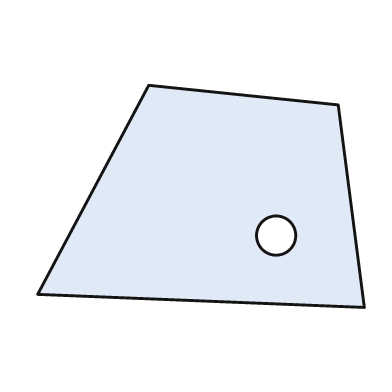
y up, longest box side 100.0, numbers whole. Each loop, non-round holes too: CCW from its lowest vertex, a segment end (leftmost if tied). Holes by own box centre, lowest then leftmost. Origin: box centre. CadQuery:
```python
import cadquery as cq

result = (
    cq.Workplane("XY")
    .moveTo(50.0, -34.0)
    .lineTo(42.0, 28.0)
    .lineTo(-16.0, 34.0)
    .lineTo(-50.0, -30.0)
    .close()
    .moveTo(23.0, -12.0)
    .circle(6.0)
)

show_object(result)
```